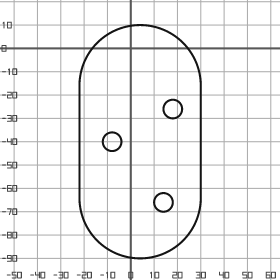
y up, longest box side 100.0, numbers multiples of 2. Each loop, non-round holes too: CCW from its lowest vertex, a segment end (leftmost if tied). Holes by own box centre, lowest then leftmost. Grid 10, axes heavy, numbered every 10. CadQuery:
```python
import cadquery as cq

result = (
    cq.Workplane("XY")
    .moveTo(-22.0, -64.0)
    .threePointArc((4.0, -90.0), (30.0, -64.0))
    .lineTo(30.0, -16.0)
    .threePointArc((4.0, 10.0), (-22.0, -16.0))
    .close()
    .moveTo(14.0, -66.0)
    .circle(4.0)
    .moveTo(-8.0, -40.0)
    .circle(4.0)
    .moveTo(18.0, -26.0)
    .circle(4.0)
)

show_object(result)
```